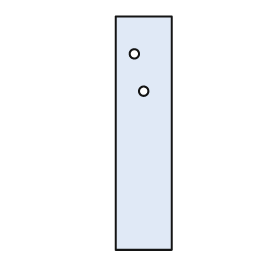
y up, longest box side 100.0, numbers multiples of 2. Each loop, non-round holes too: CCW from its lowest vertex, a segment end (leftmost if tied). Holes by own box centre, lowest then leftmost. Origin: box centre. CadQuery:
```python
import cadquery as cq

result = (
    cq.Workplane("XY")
    .moveTo(-12.0, -50.0)
    .lineTo(12.0, -50.0)
    .lineTo(12.0, 50.0)
    .lineTo(-12.0, 50.0)
    .close()
    .moveTo(0.0, 18.0)
    .circle(2.0)
    .moveTo(-4.0, 34.0)
    .circle(2.0)
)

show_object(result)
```